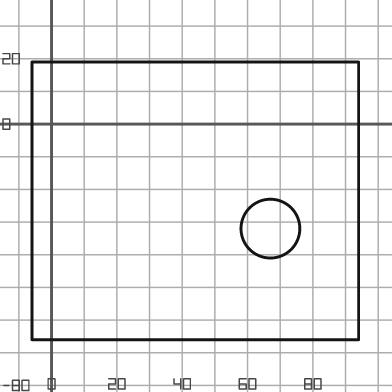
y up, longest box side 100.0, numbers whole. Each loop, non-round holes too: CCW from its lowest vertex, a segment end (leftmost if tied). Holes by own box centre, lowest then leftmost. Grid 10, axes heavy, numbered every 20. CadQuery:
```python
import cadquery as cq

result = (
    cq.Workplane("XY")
    .moveTo(-6.0, -66.0)
    .lineTo(94.0, -66.0)
    .lineTo(94.0, 19.0)
    .lineTo(-6.0, 19.0)
    .close()
    .moveTo(67.0, -32.0)
    .circle(9.0)
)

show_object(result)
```